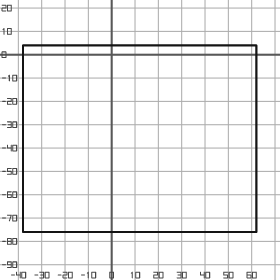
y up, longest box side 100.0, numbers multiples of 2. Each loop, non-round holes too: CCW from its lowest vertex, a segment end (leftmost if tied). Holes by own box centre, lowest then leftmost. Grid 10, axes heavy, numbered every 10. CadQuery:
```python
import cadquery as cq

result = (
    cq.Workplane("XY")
    .moveTo(-38.0, -76.0)
    .lineTo(62.0, -76.0)
    .lineTo(62.0, 4.0)
    .lineTo(-38.0, 4.0)
    .close()
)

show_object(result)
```